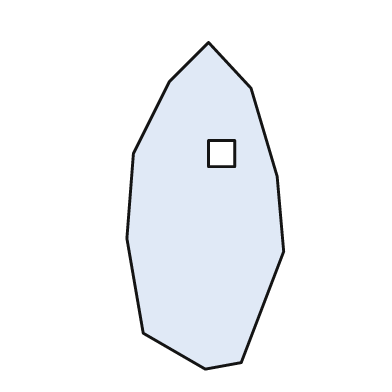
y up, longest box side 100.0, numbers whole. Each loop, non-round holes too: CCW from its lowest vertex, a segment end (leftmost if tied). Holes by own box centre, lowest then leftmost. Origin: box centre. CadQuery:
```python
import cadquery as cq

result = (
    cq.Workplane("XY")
    .moveTo(0.0, -50.0)
    .lineTo(11.0, -48.0)
    .lineTo(24.0, -14.0)
    .lineTo(22.0, 9.0)
    .lineTo(14.0, 36.0)
    .lineTo(1.0, 50.0)
    .lineTo(-11.0, 38.0)
    .lineTo(-22.0, 16.0)
    .lineTo(-24.0, -10.0)
    .lineTo(-19.0, -39.0)
    .close()
    .moveTo(1.0, 12.0)
    .lineTo(9.0, 12.0)
    .lineTo(9.0, 20.0)
    .lineTo(1.0, 20.0)
    .close()
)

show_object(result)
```